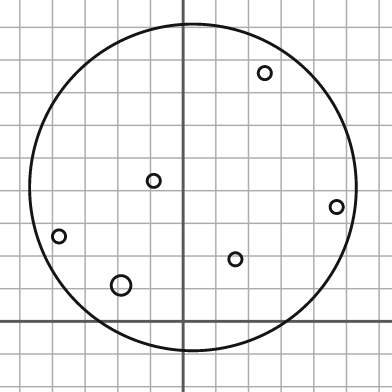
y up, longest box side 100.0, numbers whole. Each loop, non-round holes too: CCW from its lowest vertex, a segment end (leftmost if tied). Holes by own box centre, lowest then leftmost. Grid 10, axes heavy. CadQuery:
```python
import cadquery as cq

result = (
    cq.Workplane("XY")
    .moveTo(3.0, 41.0)
    .circle(50.0)
    .moveTo(-19.0, 11.0)
    .circle(3.0)
    .moveTo(16.0, 19.0)
    .circle(2.0)
    .moveTo(-38.0, 26.0)
    .circle(2.0)
    .moveTo(47.0, 35.0)
    .circle(2.0)
    .moveTo(-9.0, 43.0)
    .circle(2.0)
    .moveTo(25.0, 76.0)
    .circle(2.0)
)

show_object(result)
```